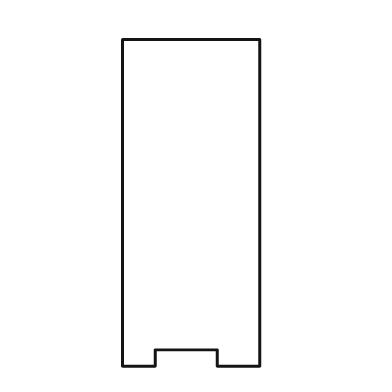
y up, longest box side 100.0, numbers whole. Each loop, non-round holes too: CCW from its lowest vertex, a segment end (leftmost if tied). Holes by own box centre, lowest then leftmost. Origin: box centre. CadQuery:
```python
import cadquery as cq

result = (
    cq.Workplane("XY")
    .moveTo(-21.0, -50.0)
    .lineTo(-11.0, -50.0)
    .lineTo(-11.0, -45.0)
    .lineTo(8.0, -45.0)
    .lineTo(8.0, -50.0)
    .lineTo(21.0, -50.0)
    .lineTo(21.0, 50.0)
    .lineTo(-21.0, 50.0)
    .close()
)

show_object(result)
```